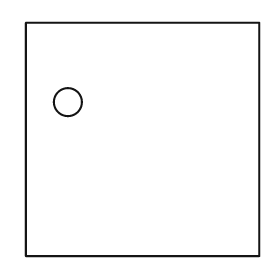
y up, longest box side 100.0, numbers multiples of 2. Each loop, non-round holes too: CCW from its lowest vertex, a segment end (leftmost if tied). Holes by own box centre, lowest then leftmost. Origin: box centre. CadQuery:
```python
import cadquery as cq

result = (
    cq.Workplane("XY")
    .moveTo(-50.0, -50.0)
    .lineTo(50.0, -50.0)
    .lineTo(50.0, 50.0)
    .lineTo(-50.0, 50.0)
    .close()
    .moveTo(-32.0, 16.0)
    .circle(6.0)
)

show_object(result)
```